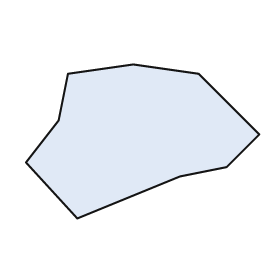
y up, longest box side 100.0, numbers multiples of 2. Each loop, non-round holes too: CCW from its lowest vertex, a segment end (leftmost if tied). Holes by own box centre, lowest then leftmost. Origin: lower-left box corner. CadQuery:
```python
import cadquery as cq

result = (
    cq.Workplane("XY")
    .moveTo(22.0, 0.0)
    .lineTo(66.0, 18.0)
    .lineTo(86.0, 22.0)
    .lineTo(100.0, 36.0)
    .lineTo(74.0, 62.0)
    .lineTo(46.0, 66.0)
    .lineTo(18.0, 62.0)
    .lineTo(14.0, 42.0)
    .lineTo(0.0, 24.0)
    .close()
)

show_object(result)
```